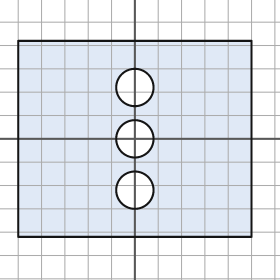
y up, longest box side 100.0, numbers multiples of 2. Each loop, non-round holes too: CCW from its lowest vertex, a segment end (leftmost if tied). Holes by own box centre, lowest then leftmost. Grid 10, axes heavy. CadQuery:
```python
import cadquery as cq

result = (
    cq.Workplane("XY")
    .moveTo(-50.0, -42.0)
    .lineTo(50.0, -42.0)
    .lineTo(50.0, 42.0)
    .lineTo(-50.0, 42.0)
    .close()
    .moveTo(0.0, -22.0)
    .circle(8.0)
    .moveTo(0.0, 0.0)
    .circle(8.0)
    .moveTo(0.0, 22.0)
    .circle(8.0)
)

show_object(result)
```